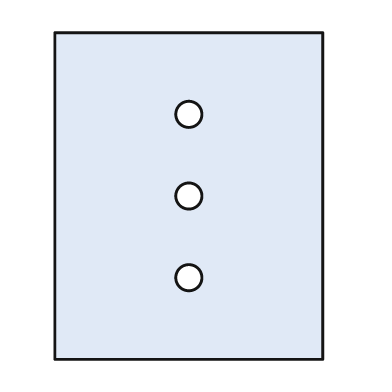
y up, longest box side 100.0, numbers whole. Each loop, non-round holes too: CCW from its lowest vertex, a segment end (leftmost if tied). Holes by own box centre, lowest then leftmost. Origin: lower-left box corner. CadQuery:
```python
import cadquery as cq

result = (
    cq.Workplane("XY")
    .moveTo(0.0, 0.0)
    .lineTo(82.0, 0.0)
    .lineTo(82.0, 100.0)
    .lineTo(0.0, 100.0)
    .close()
    .moveTo(41.0, 25.0)
    .circle(4.0)
    .moveTo(41.0, 50.0)
    .circle(4.0)
    .moveTo(41.0, 75.0)
    .circle(4.0)
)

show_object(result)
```